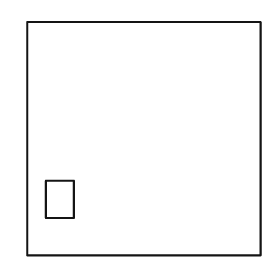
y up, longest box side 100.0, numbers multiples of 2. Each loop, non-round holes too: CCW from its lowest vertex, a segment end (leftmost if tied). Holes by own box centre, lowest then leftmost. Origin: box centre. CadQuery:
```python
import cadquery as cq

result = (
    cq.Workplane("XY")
    .moveTo(-50.0, -50.0)
    .lineTo(50.0, -50.0)
    .lineTo(50.0, 50.0)
    .lineTo(-50.0, 50.0)
    .close()
    .moveTo(-42.0, -34.0)
    .lineTo(-30.0, -34.0)
    .lineTo(-30.0, -18.0)
    .lineTo(-42.0, -18.0)
    .close()
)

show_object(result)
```